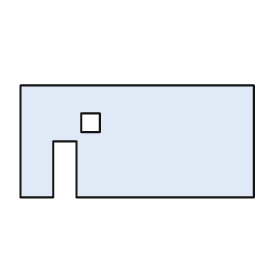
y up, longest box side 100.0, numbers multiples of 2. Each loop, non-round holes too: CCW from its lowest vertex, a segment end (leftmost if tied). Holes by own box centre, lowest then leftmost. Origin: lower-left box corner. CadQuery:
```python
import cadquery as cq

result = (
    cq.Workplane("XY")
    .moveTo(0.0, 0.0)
    .lineTo(14.0, 0.0)
    .lineTo(14.0, 24.0)
    .lineTo(24.0, 24.0)
    .lineTo(24.0, 0.0)
    .lineTo(100.0, 0.0)
    .lineTo(100.0, 48.0)
    .lineTo(0.0, 48.0)
    .close()
    .moveTo(26.0, 28.0)
    .lineTo(34.0, 28.0)
    .lineTo(34.0, 36.0)
    .lineTo(26.0, 36.0)
    .close()
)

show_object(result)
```